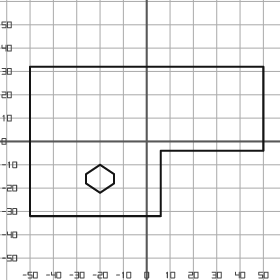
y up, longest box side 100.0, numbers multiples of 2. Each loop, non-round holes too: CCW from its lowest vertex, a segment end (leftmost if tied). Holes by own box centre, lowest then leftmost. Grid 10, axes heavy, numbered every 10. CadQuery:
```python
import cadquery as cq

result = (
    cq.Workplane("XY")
    .moveTo(-50.0, -32.0)
    .lineTo(6.0, -32.0)
    .lineTo(6.0, -4.0)
    .lineTo(50.0, -4.0)
    .lineTo(50.0, 32.0)
    .lineTo(-50.0, 32.0)
    .close()
    .moveTo(-20.0, -22.0)
    .lineTo(-14.0, -18.0)
    .lineTo(-14.0, -14.0)
    .lineTo(-20.0, -10.0)
    .lineTo(-26.0, -14.0)
    .lineTo(-26.0, -18.0)
    .close()
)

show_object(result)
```